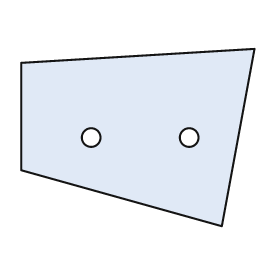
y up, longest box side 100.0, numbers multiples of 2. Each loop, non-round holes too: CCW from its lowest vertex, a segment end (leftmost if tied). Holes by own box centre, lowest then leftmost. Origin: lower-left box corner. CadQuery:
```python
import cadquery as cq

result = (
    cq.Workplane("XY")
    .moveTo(86.0, 0.0)
    .lineTo(100.0, 76.0)
    .lineTo(0.0, 70.0)
    .lineTo(0.0, 24.0)
    .close()
    .moveTo(30.0, 38.0)
    .circle(4.0)
    .moveTo(72.0, 38.0)
    .circle(4.0)
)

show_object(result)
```